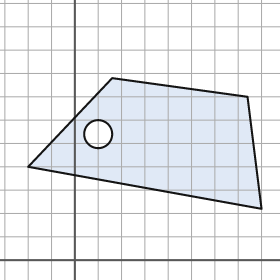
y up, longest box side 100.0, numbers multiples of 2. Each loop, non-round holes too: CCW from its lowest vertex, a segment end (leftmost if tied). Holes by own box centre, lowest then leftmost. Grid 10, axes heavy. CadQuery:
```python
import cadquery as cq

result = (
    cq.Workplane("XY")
    .moveTo(80.0, 22.0)
    .lineTo(74.0, 70.0)
    .lineTo(16.0, 78.0)
    .lineTo(-20.0, 40.0)
    .close()
    .moveTo(10.0, 54.0)
    .circle(6.0)
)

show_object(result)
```